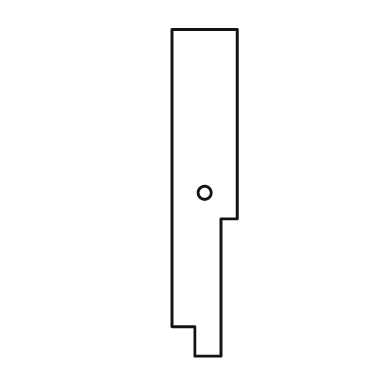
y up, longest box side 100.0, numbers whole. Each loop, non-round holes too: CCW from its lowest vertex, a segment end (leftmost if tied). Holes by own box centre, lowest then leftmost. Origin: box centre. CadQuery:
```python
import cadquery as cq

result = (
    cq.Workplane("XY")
    .moveTo(-3.0, -50.0)
    .lineTo(5.0, -50.0)
    .lineTo(5.0, -8.0)
    .lineTo(10.0, -8.0)
    .lineTo(10.0, 50.0)
    .lineTo(-10.0, 50.0)
    .lineTo(-10.0, -41.0)
    .lineTo(-3.0, -41.0)
    .close()
    .moveTo(0.0, 0.0)
    .circle(2.0)
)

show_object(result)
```